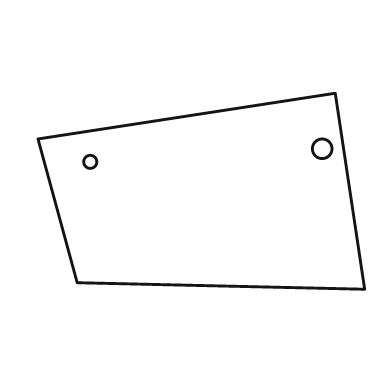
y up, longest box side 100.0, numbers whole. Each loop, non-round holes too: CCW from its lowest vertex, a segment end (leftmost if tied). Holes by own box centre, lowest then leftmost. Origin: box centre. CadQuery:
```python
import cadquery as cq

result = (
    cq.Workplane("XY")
    .moveTo(50.0, -30.0)
    .lineTo(41.0, 30.0)
    .lineTo(-50.0, 16.0)
    .lineTo(-38.0, -28.0)
    .close()
    .moveTo(-34.0, 9.0)
    .circle(2.0)
    .moveTo(37.0, 13.0)
    .circle(3.0)
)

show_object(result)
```